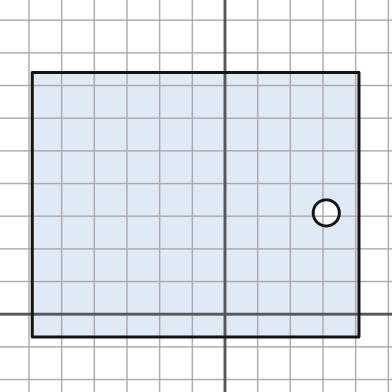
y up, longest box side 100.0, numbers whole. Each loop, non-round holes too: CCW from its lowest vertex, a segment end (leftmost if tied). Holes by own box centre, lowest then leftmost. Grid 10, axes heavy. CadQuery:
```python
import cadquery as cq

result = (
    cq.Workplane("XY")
    .moveTo(-59.0, -7.0)
    .lineTo(41.0, -7.0)
    .lineTo(41.0, 74.0)
    .lineTo(-59.0, 74.0)
    .close()
    .moveTo(31.0, 31.0)
    .circle(4.0)
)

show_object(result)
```